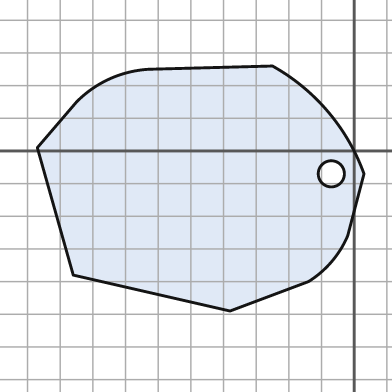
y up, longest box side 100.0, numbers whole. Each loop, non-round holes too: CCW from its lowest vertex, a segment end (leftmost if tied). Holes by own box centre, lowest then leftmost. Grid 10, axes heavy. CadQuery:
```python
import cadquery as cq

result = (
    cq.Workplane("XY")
    .moveTo(-38.0, -49.0)
    .lineTo(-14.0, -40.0)
    .threePointArc((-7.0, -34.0), (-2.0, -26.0))
    .lineTo(3.0, -7.0)
    .threePointArc((-8.0, 12.0), (-25.0, 26.0))
    .lineTo(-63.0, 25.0)
    .threePointArc((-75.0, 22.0), (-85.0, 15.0))
    .lineTo(-97.0, 1.0)
    .lineTo(-86.0, -38.0)
    .close()
    .moveTo(-7.0, -7.0)
    .circle(4.0)
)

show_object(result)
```